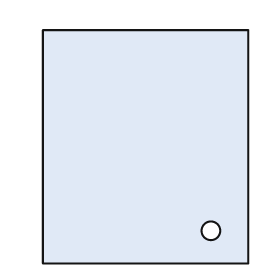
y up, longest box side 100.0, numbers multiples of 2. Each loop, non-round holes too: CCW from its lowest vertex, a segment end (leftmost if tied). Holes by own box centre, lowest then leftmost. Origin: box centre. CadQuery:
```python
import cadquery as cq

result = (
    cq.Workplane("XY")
    .moveTo(-44.0, -50.0)
    .lineTo(44.0, -50.0)
    .lineTo(44.0, 50.0)
    .lineTo(-44.0, 50.0)
    .close()
    .moveTo(28.0, -36.0)
    .circle(4.0)
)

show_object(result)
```